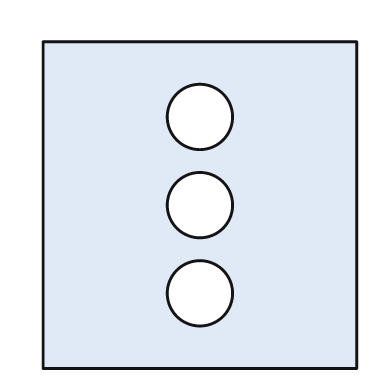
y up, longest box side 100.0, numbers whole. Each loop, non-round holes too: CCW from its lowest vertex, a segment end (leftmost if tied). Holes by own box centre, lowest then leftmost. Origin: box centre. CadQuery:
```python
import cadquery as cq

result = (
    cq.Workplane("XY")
    .moveTo(-48.0, -50.0)
    .lineTo(48.0, -50.0)
    .lineTo(48.0, 50.0)
    .lineTo(-48.0, 50.0)
    .close()
    .moveTo(0.0, -27.0)
    .circle(10.0)
    .moveTo(0.0, 0.0)
    .circle(10.0)
    .moveTo(0.0, 27.0)
    .circle(10.0)
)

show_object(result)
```